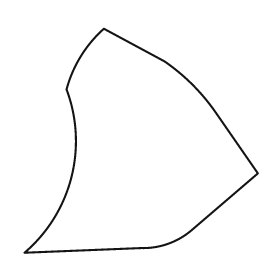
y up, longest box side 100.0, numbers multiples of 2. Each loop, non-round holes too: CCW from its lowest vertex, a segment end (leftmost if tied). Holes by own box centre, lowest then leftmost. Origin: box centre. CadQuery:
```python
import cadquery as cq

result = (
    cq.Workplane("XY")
    .moveTo(-50.0, -48.0)
    .lineTo(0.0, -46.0)
    .threePointArc((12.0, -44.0), (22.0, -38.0))
    .lineTo(50.0, -14.0)
    .lineTo(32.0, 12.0)
    .threePointArc((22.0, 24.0), (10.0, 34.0))
    .lineTo(-16.0, 48.0)
    .threePointArc((-26.0, 36.0), (-32.0, 22.0))
    .threePointArc((-30.0, -16.0), (-50.0, -48.0))
    .close()
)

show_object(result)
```